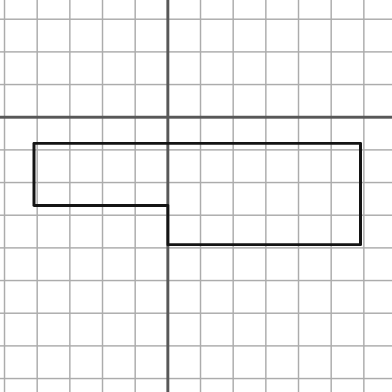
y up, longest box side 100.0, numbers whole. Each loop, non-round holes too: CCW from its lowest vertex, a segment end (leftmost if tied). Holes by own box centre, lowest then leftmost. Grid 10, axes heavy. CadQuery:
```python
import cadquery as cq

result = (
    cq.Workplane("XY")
    .moveTo(0.0, -39.0)
    .lineTo(59.0, -39.0)
    .lineTo(59.0, -8.0)
    .lineTo(-41.0, -8.0)
    .lineTo(-41.0, -27.0)
    .lineTo(0.0, -27.0)
    .close()
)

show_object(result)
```